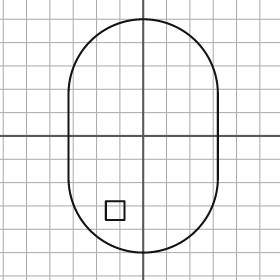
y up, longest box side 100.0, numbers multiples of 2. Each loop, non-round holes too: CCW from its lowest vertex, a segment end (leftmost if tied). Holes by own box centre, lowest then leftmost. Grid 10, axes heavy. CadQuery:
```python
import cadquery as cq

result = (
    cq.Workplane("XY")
    .moveTo(-32.0, -18.0)
    .threePointArc((0.0, -50.0), (32.0, -18.0))
    .lineTo(32.0, 18.0)
    .threePointArc((0.0, 50.0), (-32.0, 18.0))
    .close()
    .moveTo(-16.0, -36.0)
    .lineTo(-8.0, -36.0)
    .lineTo(-8.0, -28.0)
    .lineTo(-16.0, -28.0)
    .close()
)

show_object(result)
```